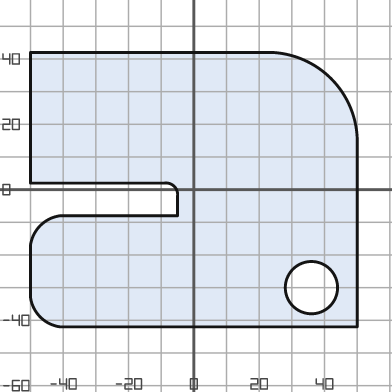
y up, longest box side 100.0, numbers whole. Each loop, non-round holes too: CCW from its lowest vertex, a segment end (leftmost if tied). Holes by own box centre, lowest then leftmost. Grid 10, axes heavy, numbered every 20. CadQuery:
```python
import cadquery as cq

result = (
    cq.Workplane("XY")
    .moveTo(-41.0, -42.0)
    .lineTo(50.0, -42.0)
    .lineTo(50.0, 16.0)
    .threePointArc((42.0, 34.0), (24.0, 42.0))
    .lineTo(-50.0, 42.0)
    .lineTo(-50.0, 2.0)
    .lineTo(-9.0, 2.0)
    .threePointArc((-6.0, 1.0), (-5.0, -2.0))
    .lineTo(-5.0, -8.0)
    .lineTo(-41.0, -8.0)
    .threePointArc((-47.0, -11.0), (-50.0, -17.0))
    .lineTo(-50.0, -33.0)
    .threePointArc((-47.0, -39.0), (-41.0, -42.0))
    .close()
    .moveTo(36.0, -30.0)
    .circle(8.0)
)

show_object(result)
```